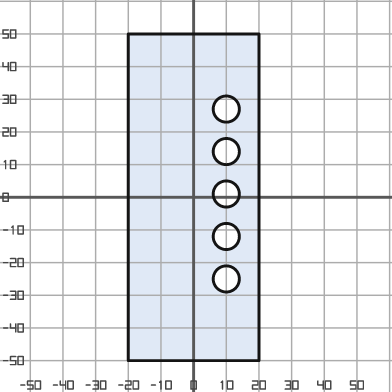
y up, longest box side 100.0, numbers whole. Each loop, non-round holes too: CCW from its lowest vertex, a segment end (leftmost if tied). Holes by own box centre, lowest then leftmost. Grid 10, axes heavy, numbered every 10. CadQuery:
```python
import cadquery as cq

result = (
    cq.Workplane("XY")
    .moveTo(-20.0, -50.0)
    .lineTo(20.0, -50.0)
    .lineTo(20.0, 50.0)
    .lineTo(-20.0, 50.0)
    .close()
    .moveTo(10.0, -25.0)
    .circle(4.0)
    .moveTo(10.0, -12.0)
    .circle(4.0)
    .moveTo(10.0, 1.0)
    .circle(4.0)
    .moveTo(10.0, 14.0)
    .circle(4.0)
    .moveTo(10.0, 27.0)
    .circle(4.0)
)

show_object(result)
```